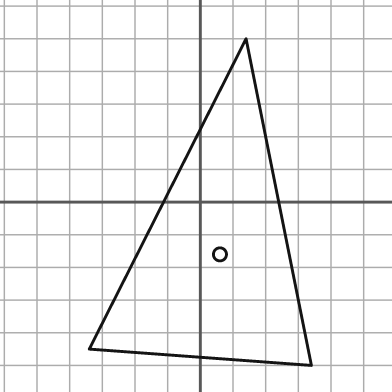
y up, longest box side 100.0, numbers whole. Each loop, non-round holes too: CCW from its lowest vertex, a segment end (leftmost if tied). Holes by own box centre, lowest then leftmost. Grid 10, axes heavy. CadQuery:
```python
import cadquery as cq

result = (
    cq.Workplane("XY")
    .moveTo(34.0, -50.0)
    .lineTo(14.0, 50.0)
    .lineTo(-34.0, -45.0)
    .close()
    .moveTo(6.0, -16.0)
    .circle(2.0)
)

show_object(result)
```